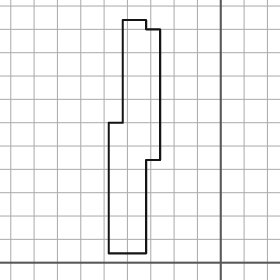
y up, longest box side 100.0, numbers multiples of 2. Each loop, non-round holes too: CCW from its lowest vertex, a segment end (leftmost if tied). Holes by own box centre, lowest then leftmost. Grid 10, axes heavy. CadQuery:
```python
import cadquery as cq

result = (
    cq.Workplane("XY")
    .moveTo(-48.0, 4.0)
    .lineTo(-32.0, 4.0)
    .lineTo(-32.0, 44.0)
    .lineTo(-26.0, 44.0)
    .lineTo(-26.0, 100.0)
    .lineTo(-32.0, 100.0)
    .lineTo(-32.0, 104.0)
    .lineTo(-42.0, 104.0)
    .lineTo(-42.0, 60.0)
    .lineTo(-48.0, 60.0)
    .close()
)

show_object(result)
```